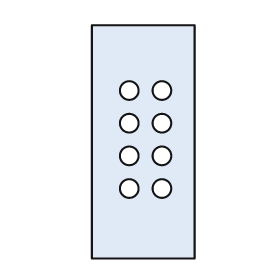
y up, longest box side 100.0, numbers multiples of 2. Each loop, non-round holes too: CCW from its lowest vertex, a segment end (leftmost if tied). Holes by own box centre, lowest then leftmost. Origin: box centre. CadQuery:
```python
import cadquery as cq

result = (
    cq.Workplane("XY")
    .moveTo(-22.0, -50.0)
    .lineTo(22.0, -50.0)
    .lineTo(22.0, 50.0)
    .lineTo(-22.0, 50.0)
    .close()
    .moveTo(-6.0, -20.0)
    .circle(4.0)
    .moveTo(8.0, -20.0)
    .circle(4.0)
    .moveTo(-6.0, -6.0)
    .circle(4.0)
    .moveTo(8.0, -6.0)
    .circle(4.0)
    .moveTo(-6.0, 8.0)
    .circle(4.0)
    .moveTo(8.0, 8.0)
    .circle(4.0)
    .moveTo(-6.0, 22.0)
    .circle(4.0)
    .moveTo(8.0, 22.0)
    .circle(4.0)
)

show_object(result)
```